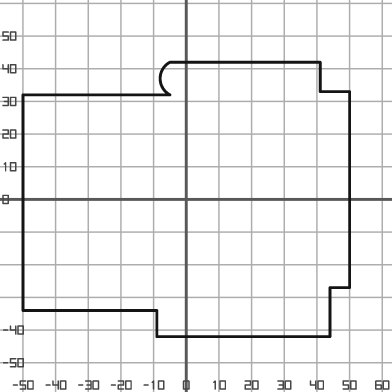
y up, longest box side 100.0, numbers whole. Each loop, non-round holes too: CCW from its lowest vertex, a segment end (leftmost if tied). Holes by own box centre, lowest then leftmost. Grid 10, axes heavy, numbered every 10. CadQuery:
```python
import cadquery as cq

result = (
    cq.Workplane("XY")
    .moveTo(-9.0, -42.0)
    .lineTo(44.0, -42.0)
    .lineTo(44.0, -27.0)
    .lineTo(50.0, -27.0)
    .lineTo(50.0, 33.0)
    .lineTo(41.0, 33.0)
    .lineTo(41.0, 42.0)
    .lineTo(-5.0, 42.0)
    .threePointArc((-8.0, 37.0), (-5.0, 32.0))
    .lineTo(-50.0, 32.0)
    .lineTo(-50.0, -34.0)
    .lineTo(-9.0, -34.0)
    .close()
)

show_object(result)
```